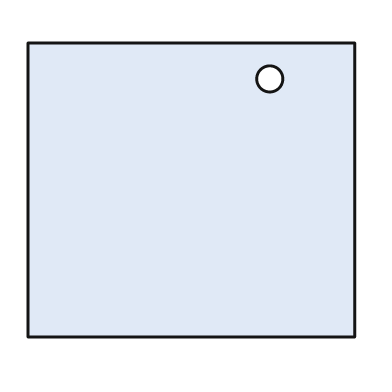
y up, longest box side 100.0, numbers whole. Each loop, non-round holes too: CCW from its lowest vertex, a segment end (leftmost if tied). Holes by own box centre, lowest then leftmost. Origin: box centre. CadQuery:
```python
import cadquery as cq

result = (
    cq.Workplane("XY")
    .moveTo(-50.0, -45.0)
    .lineTo(50.0, -45.0)
    .lineTo(50.0, 45.0)
    .lineTo(-50.0, 45.0)
    .close()
    .moveTo(24.0, 34.0)
    .circle(4.0)
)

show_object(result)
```